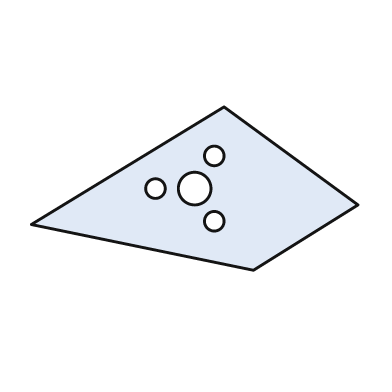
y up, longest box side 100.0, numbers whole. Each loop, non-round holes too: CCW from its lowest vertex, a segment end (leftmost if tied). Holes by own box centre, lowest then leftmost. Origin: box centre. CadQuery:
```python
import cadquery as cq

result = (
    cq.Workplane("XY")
    .moveTo(18.0, -25.0)
    .lineTo(50.0, -5.0)
    .lineTo(9.0, 25.0)
    .lineTo(-50.0, -11.0)
    .close()
    .moveTo(6.0, -10.0)
    .circle(3.0)
    .moveTo(-12.0, 0.0)
    .circle(3.0)
    .moveTo(0.0, 0.0)
    .circle(5.0)
    .moveTo(6.0, 10.0)
    .circle(3.0)
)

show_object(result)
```